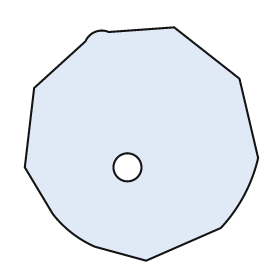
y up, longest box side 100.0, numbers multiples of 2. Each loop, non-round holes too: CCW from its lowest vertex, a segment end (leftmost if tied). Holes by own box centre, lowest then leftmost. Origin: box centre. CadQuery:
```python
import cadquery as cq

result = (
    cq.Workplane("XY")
    .moveTo(2.0, -50.0)
    .lineTo(34.0, -36.0)
    .threePointArc((44.0, -22.0), (50.0, -6.0))
    .lineTo(42.0, 28.0)
    .lineTo(14.0, 50.0)
    .lineTo(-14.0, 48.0)
    .threePointArc((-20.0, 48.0), (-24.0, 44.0))
    .lineTo(-46.0, 24.0)
    .lineTo(-50.0, -10.0)
    .lineTo(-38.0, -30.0)
    .threePointArc((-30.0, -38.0), (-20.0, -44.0))
    .close()
    .moveTo(-6.0, -10.0)
    .circle(6.0)
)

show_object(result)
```